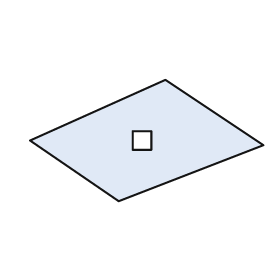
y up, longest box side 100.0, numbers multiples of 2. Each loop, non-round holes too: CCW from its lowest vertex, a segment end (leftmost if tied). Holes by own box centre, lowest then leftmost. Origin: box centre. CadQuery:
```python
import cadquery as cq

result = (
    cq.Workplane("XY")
    .moveTo(-12.0, -26.0)
    .lineTo(50.0, -2.0)
    .lineTo(8.0, 26.0)
    .lineTo(-50.0, 0.0)
    .close()
    .moveTo(-6.0, -4.0)
    .lineTo(2.0, -4.0)
    .lineTo(2.0, 4.0)
    .lineTo(-6.0, 4.0)
    .close()
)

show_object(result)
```